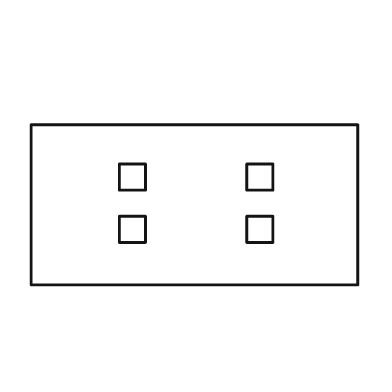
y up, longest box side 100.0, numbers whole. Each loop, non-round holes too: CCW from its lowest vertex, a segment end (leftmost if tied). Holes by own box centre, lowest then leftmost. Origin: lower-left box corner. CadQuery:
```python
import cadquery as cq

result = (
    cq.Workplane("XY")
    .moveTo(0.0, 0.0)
    .lineTo(100.0, 0.0)
    .lineTo(100.0, 49.0)
    .lineTo(0.0, 49.0)
    .close()
    .moveTo(27.0, 13.0)
    .lineTo(35.0, 13.0)
    .lineTo(35.0, 21.0)
    .lineTo(27.0, 21.0)
    .close()
    .moveTo(66.0, 13.0)
    .lineTo(74.0, 13.0)
    .lineTo(74.0, 21.0)
    .lineTo(66.0, 21.0)
    .close()
    .moveTo(27.0, 29.0)
    .lineTo(35.0, 29.0)
    .lineTo(35.0, 37.0)
    .lineTo(27.0, 37.0)
    .close()
    .moveTo(66.0, 29.0)
    .lineTo(74.0, 29.0)
    .lineTo(74.0, 37.0)
    .lineTo(66.0, 37.0)
    .close()
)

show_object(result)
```